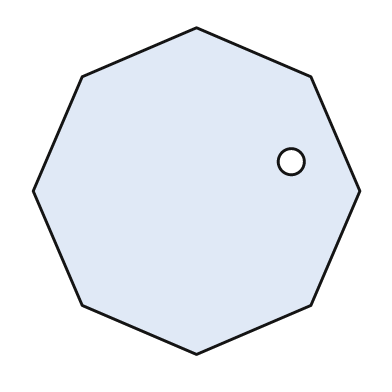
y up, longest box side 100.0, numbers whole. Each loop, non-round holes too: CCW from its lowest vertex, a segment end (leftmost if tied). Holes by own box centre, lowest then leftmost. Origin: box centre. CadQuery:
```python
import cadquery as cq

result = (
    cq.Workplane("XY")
    .moveTo(0.0, -50.0)
    .lineTo(35.0, -35.0)
    .lineTo(50.0, 0.0)
    .lineTo(35.0, 35.0)
    .lineTo(0.0, 50.0)
    .lineTo(-35.0, 35.0)
    .lineTo(-50.0, 0.0)
    .lineTo(-35.0, -35.0)
    .close()
    .moveTo(29.0, 9.0)
    .circle(4.0)
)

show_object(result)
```